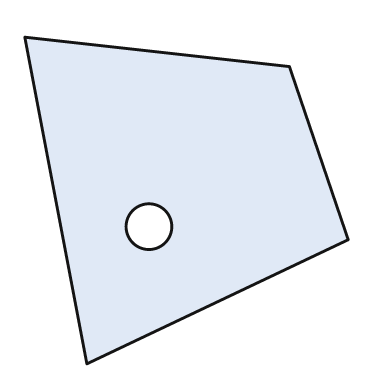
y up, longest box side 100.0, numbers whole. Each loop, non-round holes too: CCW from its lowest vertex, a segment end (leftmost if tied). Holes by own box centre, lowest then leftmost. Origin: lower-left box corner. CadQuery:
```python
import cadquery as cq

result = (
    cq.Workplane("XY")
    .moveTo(19.0, 0.0)
    .lineTo(99.0, 38.0)
    .lineTo(81.0, 91.0)
    .lineTo(0.0, 100.0)
    .close()
    .moveTo(38.0, 42.0)
    .circle(7.0)
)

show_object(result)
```